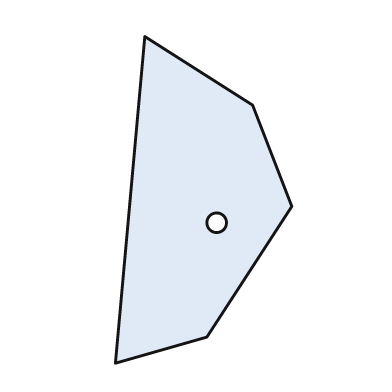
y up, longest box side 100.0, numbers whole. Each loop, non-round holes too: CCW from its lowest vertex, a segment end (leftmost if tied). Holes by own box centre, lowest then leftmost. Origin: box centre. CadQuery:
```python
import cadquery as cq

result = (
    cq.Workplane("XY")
    .moveTo(-27.0, -50.0)
    .lineTo(1.0, -42.0)
    .lineTo(27.0, -2.0)
    .lineTo(15.0, 29.0)
    .lineTo(-18.0, 50.0)
    .close()
    .moveTo(4.0, -7.0)
    .circle(3.0)
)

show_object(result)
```